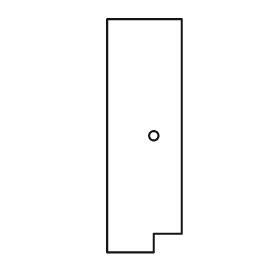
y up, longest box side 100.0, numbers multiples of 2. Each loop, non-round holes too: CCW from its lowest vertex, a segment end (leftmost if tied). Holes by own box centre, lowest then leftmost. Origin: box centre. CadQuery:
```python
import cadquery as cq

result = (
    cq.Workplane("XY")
    .moveTo(-16.0, -50.0)
    .lineTo(4.0, -50.0)
    .lineTo(4.0, -42.0)
    .lineTo(16.0, -42.0)
    .lineTo(16.0, 50.0)
    .lineTo(-16.0, 50.0)
    .close()
    .moveTo(4.0, 0.0)
    .circle(2.0)
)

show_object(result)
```